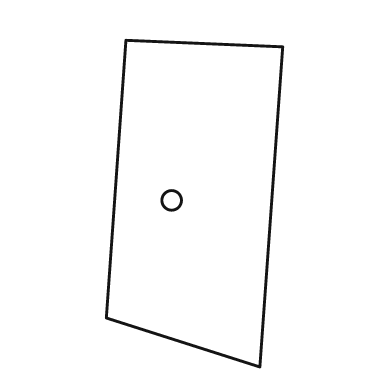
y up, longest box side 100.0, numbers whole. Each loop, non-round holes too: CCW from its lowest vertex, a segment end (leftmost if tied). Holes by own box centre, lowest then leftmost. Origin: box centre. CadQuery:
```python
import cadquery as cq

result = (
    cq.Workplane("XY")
    .moveTo(20.0, -50.0)
    .lineTo(27.0, 48.0)
    .lineTo(-21.0, 50.0)
    .lineTo(-27.0, -35.0)
    .close()
    .moveTo(-7.0, 1.0)
    .circle(3.0)
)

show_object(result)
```